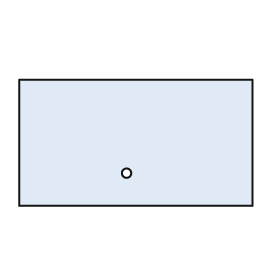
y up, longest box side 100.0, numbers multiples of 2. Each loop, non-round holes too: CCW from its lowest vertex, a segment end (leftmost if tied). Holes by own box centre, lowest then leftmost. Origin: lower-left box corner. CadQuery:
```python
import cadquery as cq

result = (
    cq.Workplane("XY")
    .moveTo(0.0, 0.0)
    .lineTo(100.0, 0.0)
    .lineTo(100.0, 54.0)
    .lineTo(0.0, 54.0)
    .close()
    .moveTo(46.0, 14.0)
    .circle(2.0)
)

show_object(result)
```